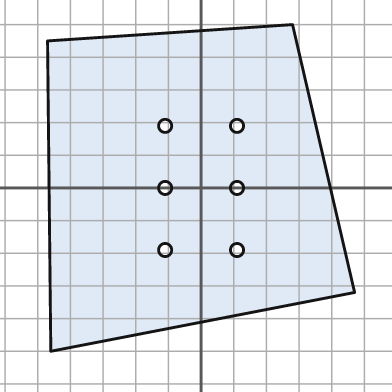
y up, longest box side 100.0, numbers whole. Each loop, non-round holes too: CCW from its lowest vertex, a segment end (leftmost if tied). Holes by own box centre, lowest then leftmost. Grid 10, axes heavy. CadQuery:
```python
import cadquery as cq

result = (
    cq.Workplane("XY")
    .moveTo(-46.0, -50.0)
    .lineTo(47.0, -32.0)
    .lineTo(28.0, 50.0)
    .lineTo(-47.0, 45.0)
    .close()
    .moveTo(-11.0, -19.0)
    .circle(2.0)
    .moveTo(11.0, -19.0)
    .circle(2.0)
    .moveTo(-11.0, 0.0)
    .circle(2.0)
    .moveTo(11.0, 0.0)
    .circle(2.0)
    .moveTo(-11.0, 19.0)
    .circle(2.0)
    .moveTo(11.0, 19.0)
    .circle(2.0)
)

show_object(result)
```